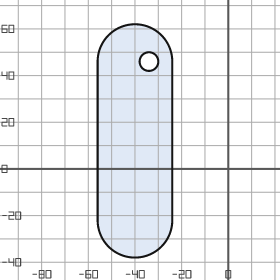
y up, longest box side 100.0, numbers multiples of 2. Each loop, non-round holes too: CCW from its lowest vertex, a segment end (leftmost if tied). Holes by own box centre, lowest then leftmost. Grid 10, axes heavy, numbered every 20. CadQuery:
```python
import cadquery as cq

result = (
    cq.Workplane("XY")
    .moveTo(-56.0, -22.0)
    .threePointArc((-40.0, -38.0), (-24.0, -22.0))
    .lineTo(-24.0, 46.0)
    .threePointArc((-40.0, 62.0), (-56.0, 46.0))
    .close()
    .moveTo(-34.0, 46.0)
    .circle(4.0)
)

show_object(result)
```